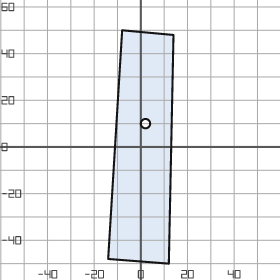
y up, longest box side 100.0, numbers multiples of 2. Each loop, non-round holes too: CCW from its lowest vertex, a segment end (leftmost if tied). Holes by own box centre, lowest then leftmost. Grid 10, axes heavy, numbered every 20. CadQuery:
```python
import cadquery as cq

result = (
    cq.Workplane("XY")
    .moveTo(12.0, -50.0)
    .lineTo(14.0, 48.0)
    .lineTo(-8.0, 50.0)
    .lineTo(-14.0, -48.0)
    .close()
    .moveTo(2.0, 10.0)
    .circle(2.0)
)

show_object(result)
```